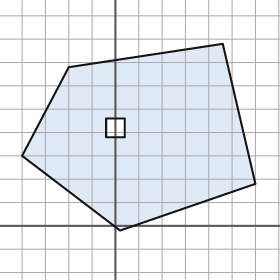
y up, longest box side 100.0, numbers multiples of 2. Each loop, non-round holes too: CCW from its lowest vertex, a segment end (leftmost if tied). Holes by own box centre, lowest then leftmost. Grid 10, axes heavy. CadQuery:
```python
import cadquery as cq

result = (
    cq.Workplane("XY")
    .moveTo(2.0, -2.0)
    .lineTo(60.0, 18.0)
    .lineTo(46.0, 78.0)
    .lineTo(-20.0, 68.0)
    .lineTo(-40.0, 30.0)
    .close()
    .moveTo(-4.0, 38.0)
    .lineTo(4.0, 38.0)
    .lineTo(4.0, 46.0)
    .lineTo(-4.0, 46.0)
    .close()
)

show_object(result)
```